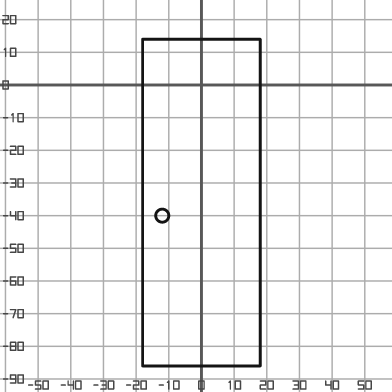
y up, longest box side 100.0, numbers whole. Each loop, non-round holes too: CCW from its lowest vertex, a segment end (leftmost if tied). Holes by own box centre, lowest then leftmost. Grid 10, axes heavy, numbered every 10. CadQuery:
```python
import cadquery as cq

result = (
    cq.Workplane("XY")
    .moveTo(-18.0, -86.0)
    .lineTo(18.0, -86.0)
    .lineTo(18.0, 14.0)
    .lineTo(-18.0, 14.0)
    .close()
    .moveTo(-12.0, -40.0)
    .circle(2.0)
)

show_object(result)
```